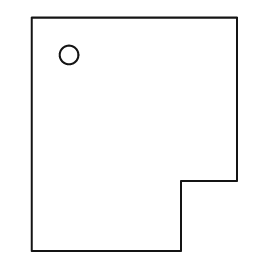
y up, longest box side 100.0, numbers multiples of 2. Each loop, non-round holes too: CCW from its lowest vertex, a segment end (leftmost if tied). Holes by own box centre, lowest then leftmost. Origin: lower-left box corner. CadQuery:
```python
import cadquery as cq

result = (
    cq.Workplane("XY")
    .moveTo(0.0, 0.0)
    .lineTo(64.0, 0.0)
    .lineTo(64.0, 30.0)
    .lineTo(88.0, 30.0)
    .lineTo(88.0, 100.0)
    .lineTo(0.0, 100.0)
    .close()
    .moveTo(16.0, 84.0)
    .circle(4.0)
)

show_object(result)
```